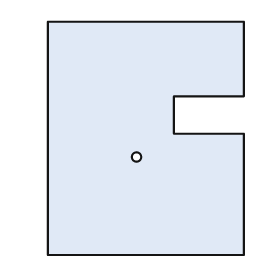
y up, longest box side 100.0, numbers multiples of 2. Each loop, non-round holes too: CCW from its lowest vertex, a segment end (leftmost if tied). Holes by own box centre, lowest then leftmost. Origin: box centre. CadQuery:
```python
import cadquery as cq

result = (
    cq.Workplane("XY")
    .moveTo(-42.0, -50.0)
    .lineTo(42.0, -50.0)
    .lineTo(42.0, 2.0)
    .lineTo(12.0, 2.0)
    .lineTo(12.0, 18.0)
    .lineTo(42.0, 18.0)
    .lineTo(42.0, 50.0)
    .lineTo(-42.0, 50.0)
    .close()
    .moveTo(-4.0, -8.0)
    .circle(2.0)
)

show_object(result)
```